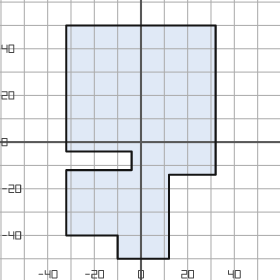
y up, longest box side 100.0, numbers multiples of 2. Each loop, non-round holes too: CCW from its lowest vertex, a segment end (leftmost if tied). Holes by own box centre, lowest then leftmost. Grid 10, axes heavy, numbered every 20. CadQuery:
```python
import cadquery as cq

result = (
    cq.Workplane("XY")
    .moveTo(-10.0, -50.0)
    .lineTo(12.0, -50.0)
    .lineTo(12.0, -14.0)
    .lineTo(32.0, -14.0)
    .lineTo(32.0, 50.0)
    .lineTo(-32.0, 50.0)
    .lineTo(-32.0, -4.0)
    .lineTo(-4.0, -4.0)
    .lineTo(-4.0, -12.0)
    .lineTo(-32.0, -12.0)
    .lineTo(-32.0, -40.0)
    .lineTo(-10.0, -40.0)
    .close()
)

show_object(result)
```